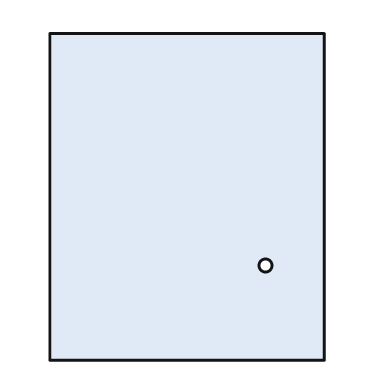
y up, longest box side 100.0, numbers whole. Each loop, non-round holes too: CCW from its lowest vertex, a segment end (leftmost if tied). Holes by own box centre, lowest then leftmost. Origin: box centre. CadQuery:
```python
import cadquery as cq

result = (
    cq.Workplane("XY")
    .moveTo(-42.0, -50.0)
    .lineTo(42.0, -50.0)
    .lineTo(42.0, 50.0)
    .lineTo(-42.0, 50.0)
    .close()
    .moveTo(24.0, -21.0)
    .circle(2.0)
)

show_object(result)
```